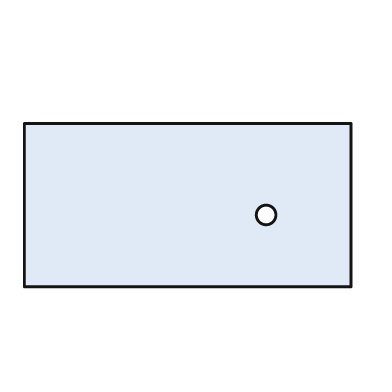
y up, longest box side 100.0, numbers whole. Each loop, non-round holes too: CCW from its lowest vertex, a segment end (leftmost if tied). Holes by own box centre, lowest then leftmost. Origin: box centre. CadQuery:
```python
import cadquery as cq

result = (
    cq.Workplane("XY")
    .moveTo(-50.0, -25.0)
    .lineTo(50.0, -25.0)
    .lineTo(50.0, 25.0)
    .lineTo(-50.0, 25.0)
    .close()
    .moveTo(24.0, -3.0)
    .circle(3.0)
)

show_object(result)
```